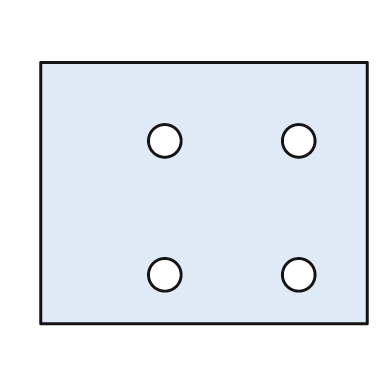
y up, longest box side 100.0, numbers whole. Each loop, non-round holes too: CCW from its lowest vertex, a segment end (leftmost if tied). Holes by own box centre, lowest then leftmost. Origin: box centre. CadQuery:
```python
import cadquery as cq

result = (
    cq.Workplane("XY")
    .moveTo(-50.0, -40.0)
    .lineTo(50.0, -40.0)
    .lineTo(50.0, 40.0)
    .lineTo(-50.0, 40.0)
    .close()
    .moveTo(-12.0, -25.0)
    .circle(5.0)
    .moveTo(29.0, -25.0)
    .circle(5.0)
    .moveTo(-12.0, 16.0)
    .circle(5.0)
    .moveTo(29.0, 16.0)
    .circle(5.0)
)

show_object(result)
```